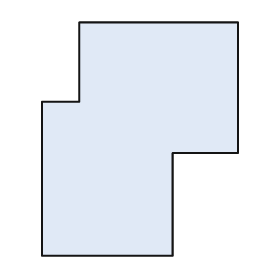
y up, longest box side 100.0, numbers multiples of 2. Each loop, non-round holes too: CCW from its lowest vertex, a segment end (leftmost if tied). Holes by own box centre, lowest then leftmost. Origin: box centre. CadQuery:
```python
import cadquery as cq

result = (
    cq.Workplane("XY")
    .moveTo(-42.0, -50.0)
    .lineTo(14.0, -50.0)
    .lineTo(14.0, -6.0)
    .lineTo(42.0, -6.0)
    .lineTo(42.0, 50.0)
    .lineTo(-26.0, 50.0)
    .lineTo(-26.0, 16.0)
    .lineTo(-42.0, 16.0)
    .close()
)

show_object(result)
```